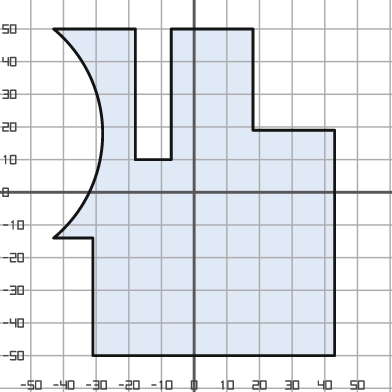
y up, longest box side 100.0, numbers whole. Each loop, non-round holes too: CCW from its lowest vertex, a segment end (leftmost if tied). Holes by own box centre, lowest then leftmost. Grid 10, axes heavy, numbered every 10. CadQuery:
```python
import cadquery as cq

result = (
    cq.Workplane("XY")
    .moveTo(-31.0, -50.0)
    .lineTo(43.0, -50.0)
    .lineTo(43.0, 19.0)
    .lineTo(18.0, 19.0)
    .lineTo(18.0, 50.0)
    .lineTo(-7.0, 50.0)
    .lineTo(-7.0, 10.0)
    .lineTo(-18.0, 10.0)
    .lineTo(-18.0, 50.0)
    .lineTo(-43.0, 50.0)
    .threePointArc((-28.0, 18.0), (-43.0, -14.0))
    .lineTo(-31.0, -14.0)
    .close()
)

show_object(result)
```